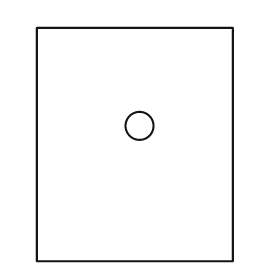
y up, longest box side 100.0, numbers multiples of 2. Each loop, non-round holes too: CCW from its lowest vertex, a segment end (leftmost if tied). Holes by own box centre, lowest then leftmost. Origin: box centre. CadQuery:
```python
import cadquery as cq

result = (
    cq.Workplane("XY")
    .moveTo(-42.0, -50.0)
    .lineTo(42.0, -50.0)
    .lineTo(42.0, 50.0)
    .lineTo(-42.0, 50.0)
    .close()
    .moveTo(2.0, 8.0)
    .circle(6.0)
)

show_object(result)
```